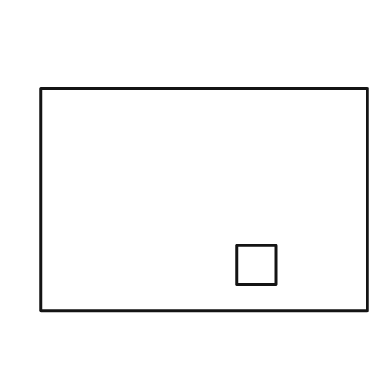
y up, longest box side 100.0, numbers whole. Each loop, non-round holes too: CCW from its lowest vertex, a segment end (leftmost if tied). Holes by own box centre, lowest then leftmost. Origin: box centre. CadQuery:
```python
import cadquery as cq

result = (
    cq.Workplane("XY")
    .moveTo(-50.0, -34.0)
    .lineTo(50.0, -34.0)
    .lineTo(50.0, 34.0)
    .lineTo(-50.0, 34.0)
    .close()
    .moveTo(10.0, -26.0)
    .lineTo(22.0, -26.0)
    .lineTo(22.0, -14.0)
    .lineTo(10.0, -14.0)
    .close()
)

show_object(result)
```